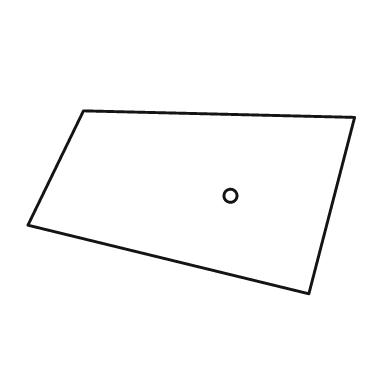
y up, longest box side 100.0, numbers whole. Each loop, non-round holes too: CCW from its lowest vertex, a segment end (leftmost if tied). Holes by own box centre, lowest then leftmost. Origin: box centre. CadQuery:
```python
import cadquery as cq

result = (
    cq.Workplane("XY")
    .moveTo(36.0, -28.0)
    .lineTo(50.0, 26.0)
    .lineTo(-33.0, 28.0)
    .lineTo(-50.0, -7.0)
    .close()
    .moveTo(12.0, 2.0)
    .circle(2.0)
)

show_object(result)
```